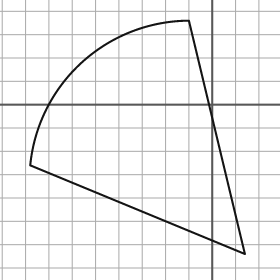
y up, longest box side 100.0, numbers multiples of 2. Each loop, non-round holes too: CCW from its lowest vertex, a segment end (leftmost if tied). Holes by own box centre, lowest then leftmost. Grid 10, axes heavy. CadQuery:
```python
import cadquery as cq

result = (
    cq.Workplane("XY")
    .moveTo(14.0, -64.0)
    .lineTo(-10.0, 36.0)
    .threePointArc((-56.0, 18.0), (-78.0, -26.0))
    .close()
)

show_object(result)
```